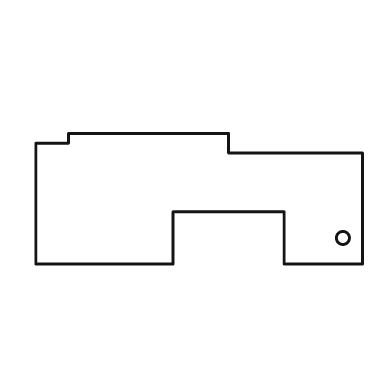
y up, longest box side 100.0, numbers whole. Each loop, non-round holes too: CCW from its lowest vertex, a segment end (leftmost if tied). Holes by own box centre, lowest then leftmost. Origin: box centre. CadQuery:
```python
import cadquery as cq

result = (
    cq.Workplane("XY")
    .moveTo(-50.0, -20.0)
    .lineTo(-8.0, -20.0)
    .lineTo(-8.0, -4.0)
    .lineTo(26.0, -4.0)
    .lineTo(26.0, -20.0)
    .lineTo(50.0, -20.0)
    .lineTo(50.0, 14.0)
    .lineTo(9.0, 14.0)
    .lineTo(9.0, 20.0)
    .lineTo(-40.0, 20.0)
    .lineTo(-40.0, 17.0)
    .lineTo(-50.0, 17.0)
    .close()
    .moveTo(44.0, -12.0)
    .circle(2.0)
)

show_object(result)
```